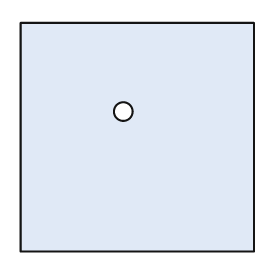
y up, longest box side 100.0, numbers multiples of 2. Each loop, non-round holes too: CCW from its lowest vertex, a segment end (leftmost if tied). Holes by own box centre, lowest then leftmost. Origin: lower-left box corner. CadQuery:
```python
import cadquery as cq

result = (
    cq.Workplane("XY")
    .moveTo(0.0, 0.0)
    .lineTo(100.0, 0.0)
    .lineTo(100.0, 98.0)
    .lineTo(0.0, 98.0)
    .close()
    .moveTo(44.0, 60.0)
    .circle(4.0)
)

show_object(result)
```